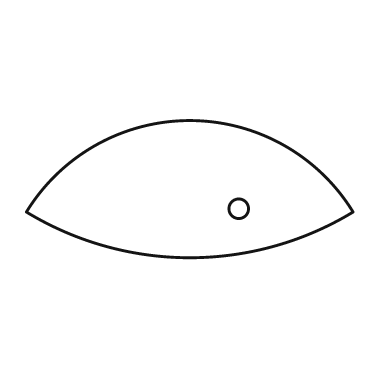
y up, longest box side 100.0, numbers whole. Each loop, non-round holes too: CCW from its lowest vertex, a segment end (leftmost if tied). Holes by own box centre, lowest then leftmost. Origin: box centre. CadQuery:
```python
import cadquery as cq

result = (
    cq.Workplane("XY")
    .moveTo(-50.0, -7.0)
    .threePointArc((0.0, -21.0), (50.0, -7.0))
    .threePointArc((0.0, 21.0), (-50.0, -7.0))
    .close()
    .moveTo(15.0, -6.0)
    .circle(3.0)
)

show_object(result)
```